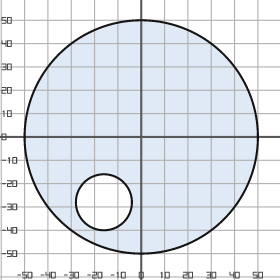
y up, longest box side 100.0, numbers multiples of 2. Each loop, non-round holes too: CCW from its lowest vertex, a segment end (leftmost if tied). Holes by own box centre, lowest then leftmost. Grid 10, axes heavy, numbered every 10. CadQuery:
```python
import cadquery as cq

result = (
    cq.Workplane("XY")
    .moveTo(0.0, 0.0)
    .circle(50.0)
    .moveTo(-16.0, -28.0)
    .circle(12.0)
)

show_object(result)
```